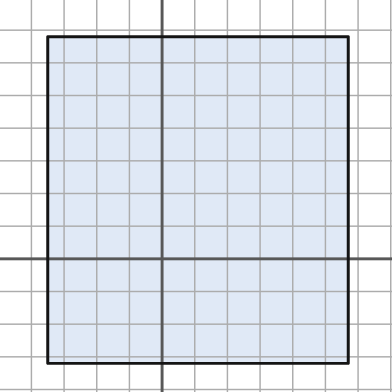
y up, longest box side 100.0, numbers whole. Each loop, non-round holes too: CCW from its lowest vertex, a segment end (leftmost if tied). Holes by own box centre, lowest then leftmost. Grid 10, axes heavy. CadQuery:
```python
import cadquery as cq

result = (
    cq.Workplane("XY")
    .moveTo(-35.0, -32.0)
    .lineTo(57.0, -32.0)
    .lineTo(57.0, 68.0)
    .lineTo(-35.0, 68.0)
    .close()
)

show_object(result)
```